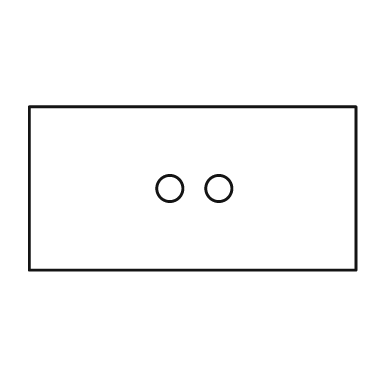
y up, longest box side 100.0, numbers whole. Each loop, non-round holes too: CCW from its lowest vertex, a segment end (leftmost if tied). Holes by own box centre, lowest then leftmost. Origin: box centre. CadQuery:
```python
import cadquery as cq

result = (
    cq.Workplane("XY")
    .moveTo(-50.0, -25.0)
    .lineTo(50.0, -25.0)
    .lineTo(50.0, 25.0)
    .lineTo(-50.0, 25.0)
    .close()
    .moveTo(-7.0, 0.0)
    .circle(4.0)
    .moveTo(8.0, 0.0)
    .circle(4.0)
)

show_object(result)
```